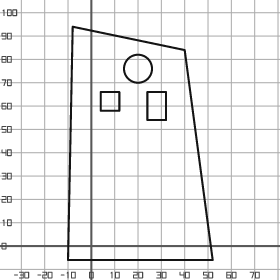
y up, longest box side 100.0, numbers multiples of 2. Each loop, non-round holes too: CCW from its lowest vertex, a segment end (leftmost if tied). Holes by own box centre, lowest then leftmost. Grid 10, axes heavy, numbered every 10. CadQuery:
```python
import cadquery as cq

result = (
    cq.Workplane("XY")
    .moveTo(-10.0, -6.0)
    .lineTo(52.0, -6.0)
    .lineTo(40.0, 84.0)
    .lineTo(-8.0, 94.0)
    .close()
    .moveTo(24.0, 54.0)
    .lineTo(32.0, 54.0)
    .lineTo(32.0, 66.0)
    .lineTo(24.0, 66.0)
    .close()
    .moveTo(4.0, 58.0)
    .lineTo(12.0, 58.0)
    .lineTo(12.0, 66.0)
    .lineTo(4.0, 66.0)
    .close()
    .moveTo(20.0, 76.0)
    .circle(6.0)
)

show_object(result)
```